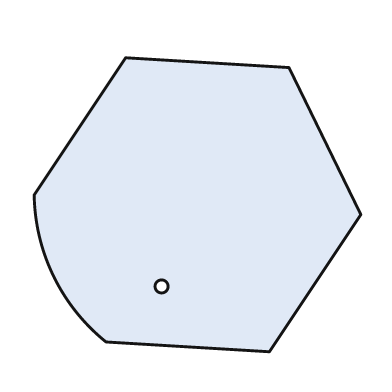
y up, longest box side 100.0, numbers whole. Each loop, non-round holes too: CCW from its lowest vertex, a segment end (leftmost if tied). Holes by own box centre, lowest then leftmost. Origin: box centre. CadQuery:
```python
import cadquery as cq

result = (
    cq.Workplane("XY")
    .moveTo(22.0, -45.0)
    .lineTo(50.0, -3.0)
    .lineTo(28.0, 42.0)
    .lineTo(-22.0, 45.0)
    .lineTo(-50.0, 3.0)
    .threePointArc((-44.0, -22.0), (-28.0, -42.0))
    .close()
    .moveTo(-11.0, -25.0)
    .circle(2.0)
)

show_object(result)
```